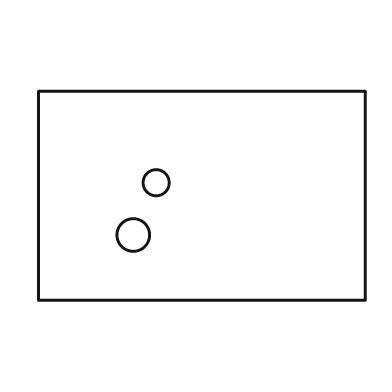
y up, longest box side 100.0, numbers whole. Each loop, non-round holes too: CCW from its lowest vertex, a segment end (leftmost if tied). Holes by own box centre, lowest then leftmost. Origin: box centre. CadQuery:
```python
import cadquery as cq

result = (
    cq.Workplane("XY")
    .moveTo(-50.0, -32.0)
    .lineTo(50.0, -32.0)
    .lineTo(50.0, 32.0)
    .lineTo(-50.0, 32.0)
    .close()
    .moveTo(-21.0, -12.0)
    .circle(5.0)
    .moveTo(-14.0, 4.0)
    .circle(4.0)
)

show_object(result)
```